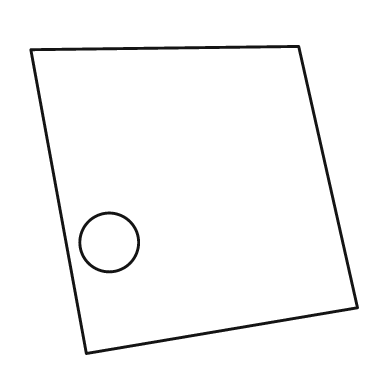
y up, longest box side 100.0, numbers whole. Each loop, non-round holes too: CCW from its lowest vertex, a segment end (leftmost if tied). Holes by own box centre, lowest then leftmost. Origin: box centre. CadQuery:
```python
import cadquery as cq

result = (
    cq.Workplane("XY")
    .moveTo(-33.0, -47.0)
    .lineTo(50.0, -33.0)
    .lineTo(32.0, 47.0)
    .lineTo(-50.0, 46.0)
    .close()
    .moveTo(-26.0, -13.0)
    .circle(9.0)
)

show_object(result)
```